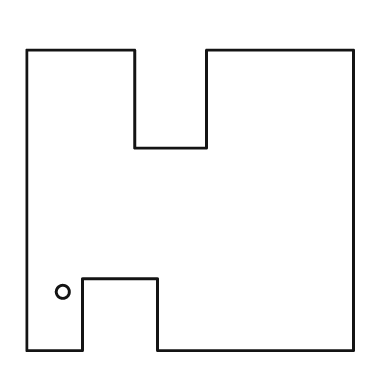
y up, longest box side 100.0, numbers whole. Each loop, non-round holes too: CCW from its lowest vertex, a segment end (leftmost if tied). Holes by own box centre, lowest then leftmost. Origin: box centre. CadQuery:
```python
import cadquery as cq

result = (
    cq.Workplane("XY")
    .moveTo(-50.0, -46.0)
    .lineTo(-33.0, -46.0)
    .lineTo(-33.0, -24.0)
    .lineTo(-10.0, -24.0)
    .lineTo(-10.0, -46.0)
    .lineTo(50.0, -46.0)
    .lineTo(50.0, 46.0)
    .lineTo(5.0, 46.0)
    .lineTo(5.0, 16.0)
    .lineTo(-17.0, 16.0)
    .lineTo(-17.0, 46.0)
    .lineTo(-50.0, 46.0)
    .close()
    .moveTo(-39.0, -28.0)
    .circle(2.0)
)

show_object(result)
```